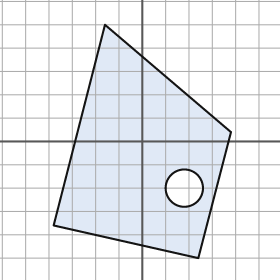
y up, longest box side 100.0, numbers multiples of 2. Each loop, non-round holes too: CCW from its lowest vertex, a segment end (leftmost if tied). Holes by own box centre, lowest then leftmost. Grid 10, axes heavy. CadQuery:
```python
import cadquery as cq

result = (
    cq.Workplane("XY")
    .moveTo(24.0, -50.0)
    .lineTo(38.0, 4.0)
    .lineTo(-16.0, 50.0)
    .lineTo(-38.0, -36.0)
    .close()
    .moveTo(18.0, -20.0)
    .circle(8.0)
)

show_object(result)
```